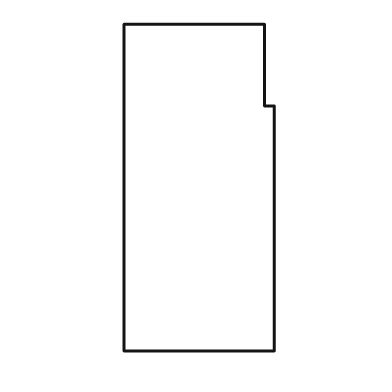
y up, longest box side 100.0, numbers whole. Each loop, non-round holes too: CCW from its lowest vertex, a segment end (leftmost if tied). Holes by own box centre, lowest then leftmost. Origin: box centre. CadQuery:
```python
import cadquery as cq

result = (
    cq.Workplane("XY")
    .moveTo(-23.0, -50.0)
    .lineTo(23.0, -50.0)
    .lineTo(23.0, 25.0)
    .lineTo(20.0, 25.0)
    .lineTo(20.0, 50.0)
    .lineTo(-23.0, 50.0)
    .close()
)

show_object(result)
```